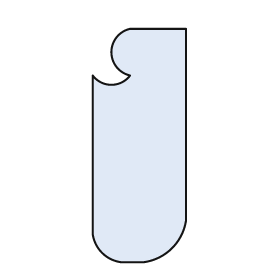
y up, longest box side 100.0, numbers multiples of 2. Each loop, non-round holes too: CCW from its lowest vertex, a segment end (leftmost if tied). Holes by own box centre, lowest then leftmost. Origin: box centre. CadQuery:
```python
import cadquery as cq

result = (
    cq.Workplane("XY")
    .moveTo(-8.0, -50.0)
    .lineTo(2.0, -50.0)
    .threePointArc((14.0, -44.0), (20.0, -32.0))
    .lineTo(20.0, 50.0)
    .lineTo(-4.0, 50.0)
    .threePointArc((-12.0, 40.0), (-4.0, 30.0))
    .threePointArc((-12.0, 26.0), (-20.0, 30.0))
    .lineTo(-20.0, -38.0)
    .threePointArc((-16.0, -46.0), (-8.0, -50.0))
    .close()
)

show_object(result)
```